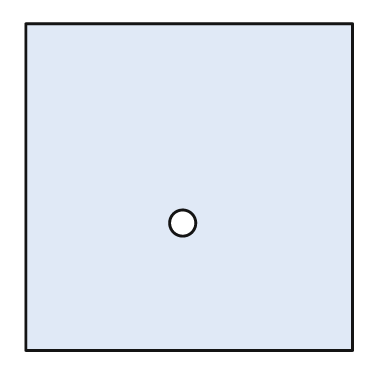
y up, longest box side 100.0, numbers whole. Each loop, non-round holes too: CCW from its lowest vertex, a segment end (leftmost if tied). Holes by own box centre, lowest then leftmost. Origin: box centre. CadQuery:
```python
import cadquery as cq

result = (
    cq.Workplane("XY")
    .moveTo(-50.0, -50.0)
    .lineTo(50.0, -50.0)
    .lineTo(50.0, 50.0)
    .lineTo(-50.0, 50.0)
    .close()
    .moveTo(-2.0, -11.0)
    .circle(4.0)
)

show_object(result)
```